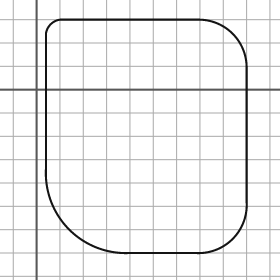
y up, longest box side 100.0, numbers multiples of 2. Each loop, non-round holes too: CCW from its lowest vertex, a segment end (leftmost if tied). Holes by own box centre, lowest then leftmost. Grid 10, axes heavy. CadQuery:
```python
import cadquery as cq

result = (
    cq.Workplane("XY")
    .moveTo(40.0, -70.0)
    .lineTo(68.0, -70.0)
    .threePointArc((84.0, -64.0), (90.0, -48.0))
    .lineTo(90.0, 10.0)
    .threePointArc((84.0, 24.0), (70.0, 30.0))
    .lineTo(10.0, 30.0)
    .threePointArc((6.0, 28.0), (4.0, 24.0))
    .lineTo(4.0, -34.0)
    .threePointArc((14.0, -60.0), (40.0, -70.0))
    .close()
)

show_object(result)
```